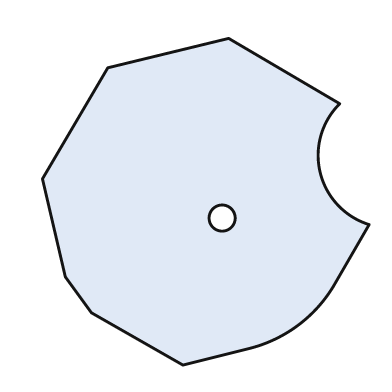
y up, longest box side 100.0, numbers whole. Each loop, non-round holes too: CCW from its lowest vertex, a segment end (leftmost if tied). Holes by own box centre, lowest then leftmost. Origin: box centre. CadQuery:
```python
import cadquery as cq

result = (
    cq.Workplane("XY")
    .moveTo(-7.0, -50.0)
    .lineTo(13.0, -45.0)
    .threePointArc((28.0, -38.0), (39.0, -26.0))
    .lineTo(50.0, -7.0)
    .threePointArc((35.0, 9.0), (41.0, 30.0))
    .lineTo(7.0, 50.0)
    .lineTo(-30.0, 41.0)
    .lineTo(-50.0, 7.0)
    .lineTo(-43.0, -23.0)
    .lineTo(-35.0, -34.0)
    .close()
    .moveTo(5.0, -5.0)
    .circle(4.0)
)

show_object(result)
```